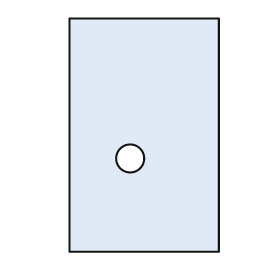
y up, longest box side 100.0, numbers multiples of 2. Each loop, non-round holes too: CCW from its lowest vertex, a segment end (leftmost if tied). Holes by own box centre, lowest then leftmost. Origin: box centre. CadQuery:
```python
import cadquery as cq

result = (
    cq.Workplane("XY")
    .moveTo(-32.0, -50.0)
    .lineTo(32.0, -50.0)
    .lineTo(32.0, 50.0)
    .lineTo(-32.0, 50.0)
    .close()
    .moveTo(-6.0, -10.0)
    .circle(6.0)
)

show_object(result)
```